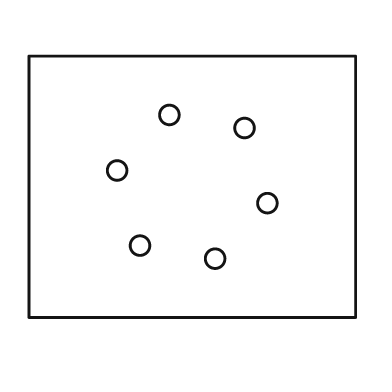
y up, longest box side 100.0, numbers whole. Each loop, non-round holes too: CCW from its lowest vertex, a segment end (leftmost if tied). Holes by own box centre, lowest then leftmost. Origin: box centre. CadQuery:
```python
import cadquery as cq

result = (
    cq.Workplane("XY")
    .moveTo(-50.0, -40.0)
    .lineTo(50.0, -40.0)
    .lineTo(50.0, 40.0)
    .lineTo(-50.0, 40.0)
    .close()
    .moveTo(7.0, -22.0)
    .circle(3.0)
    .moveTo(-16.0, -18.0)
    .circle(3.0)
    .moveTo(23.0, -5.0)
    .circle(3.0)
    .moveTo(-23.0, 5.0)
    .circle(3.0)
    .moveTo(16.0, 18.0)
    .circle(3.0)
    .moveTo(-7.0, 22.0)
    .circle(3.0)
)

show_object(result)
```